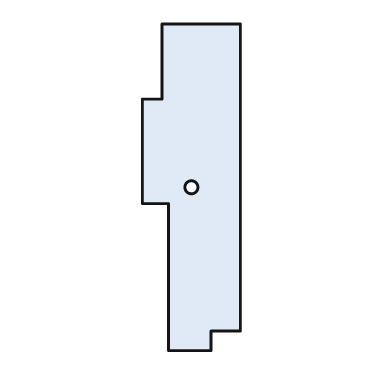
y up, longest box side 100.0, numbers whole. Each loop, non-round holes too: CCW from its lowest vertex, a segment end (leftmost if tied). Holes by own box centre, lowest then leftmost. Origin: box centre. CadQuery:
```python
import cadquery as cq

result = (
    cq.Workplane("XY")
    .moveTo(-7.0, -50.0)
    .lineTo(6.0, -50.0)
    .lineTo(6.0, -44.0)
    .lineTo(15.0, -44.0)
    .lineTo(15.0, 50.0)
    .lineTo(-9.0, 50.0)
    .lineTo(-9.0, 27.0)
    .lineTo(-15.0, 27.0)
    .lineTo(-15.0, -5.0)
    .lineTo(-7.0, -5.0)
    .close()
    .moveTo(0.0, 0.0)
    .circle(2.0)
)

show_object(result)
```